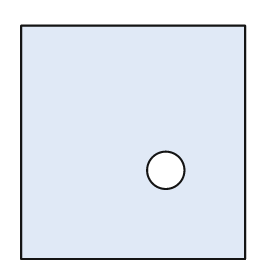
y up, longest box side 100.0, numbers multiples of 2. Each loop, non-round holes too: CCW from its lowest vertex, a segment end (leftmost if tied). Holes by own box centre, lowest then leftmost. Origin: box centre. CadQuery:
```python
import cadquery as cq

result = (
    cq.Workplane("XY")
    .moveTo(-48.0, -50.0)
    .lineTo(48.0, -50.0)
    .lineTo(48.0, 50.0)
    .lineTo(-48.0, 50.0)
    .close()
    .moveTo(14.0, -12.0)
    .circle(8.0)
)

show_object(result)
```